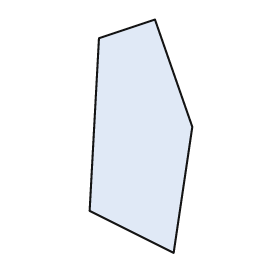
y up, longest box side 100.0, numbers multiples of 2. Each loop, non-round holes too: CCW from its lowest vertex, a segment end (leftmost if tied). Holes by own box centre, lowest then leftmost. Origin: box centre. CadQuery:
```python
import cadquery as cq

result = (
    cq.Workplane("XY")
    .moveTo(14.0, -50.0)
    .lineTo(22.0, 4.0)
    .lineTo(6.0, 50.0)
    .lineTo(-18.0, 42.0)
    .lineTo(-22.0, -32.0)
    .close()
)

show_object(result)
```